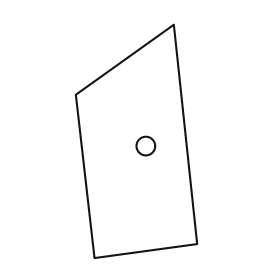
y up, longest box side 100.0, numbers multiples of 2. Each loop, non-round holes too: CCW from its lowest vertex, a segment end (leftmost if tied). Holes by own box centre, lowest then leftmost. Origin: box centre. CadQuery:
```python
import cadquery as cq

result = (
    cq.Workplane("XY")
    .moveTo(-18.0, -50.0)
    .lineTo(26.0, -44.0)
    .lineTo(16.0, 50.0)
    .lineTo(-26.0, 20.0)
    .close()
    .moveTo(4.0, -2.0)
    .circle(4.0)
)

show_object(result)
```